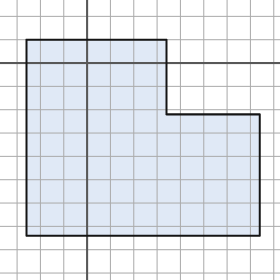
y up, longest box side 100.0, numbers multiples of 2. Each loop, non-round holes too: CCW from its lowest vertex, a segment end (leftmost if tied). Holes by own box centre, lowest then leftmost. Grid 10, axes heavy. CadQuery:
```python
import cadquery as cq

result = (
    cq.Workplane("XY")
    .moveTo(-26.0, -74.0)
    .lineTo(74.0, -74.0)
    .lineTo(74.0, -22.0)
    .lineTo(34.0, -22.0)
    .lineTo(34.0, 10.0)
    .lineTo(-26.0, 10.0)
    .close()
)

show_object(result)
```